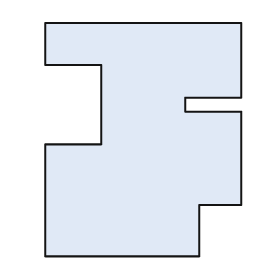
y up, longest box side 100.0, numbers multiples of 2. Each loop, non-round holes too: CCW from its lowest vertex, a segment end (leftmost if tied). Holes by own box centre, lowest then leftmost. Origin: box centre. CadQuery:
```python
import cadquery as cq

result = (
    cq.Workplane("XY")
    .moveTo(-42.0, -50.0)
    .lineTo(24.0, -50.0)
    .lineTo(24.0, -28.0)
    .lineTo(42.0, -28.0)
    .lineTo(42.0, 12.0)
    .lineTo(18.0, 12.0)
    .lineTo(18.0, 18.0)
    .lineTo(42.0, 18.0)
    .lineTo(42.0, 50.0)
    .lineTo(-42.0, 50.0)
    .lineTo(-42.0, 32.0)
    .lineTo(-18.0, 32.0)
    .lineTo(-18.0, -2.0)
    .lineTo(-42.0, -2.0)
    .close()
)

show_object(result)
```